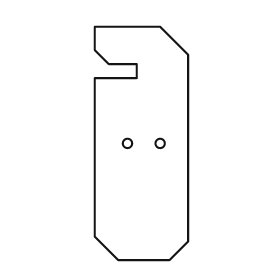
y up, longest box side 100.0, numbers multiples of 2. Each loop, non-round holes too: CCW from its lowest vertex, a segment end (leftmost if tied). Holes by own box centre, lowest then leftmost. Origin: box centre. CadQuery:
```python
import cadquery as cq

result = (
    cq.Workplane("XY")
    .moveTo(-10.0, -50.0)
    .lineTo(12.0, -50.0)
    .lineTo(20.0, -42.0)
    .lineTo(20.0, 38.0)
    .lineTo(8.0, 50.0)
    .lineTo(-20.0, 50.0)
    .lineTo(-20.0, 40.0)
    .lineTo(-14.0, 34.0)
    .lineTo(-2.0, 34.0)
    .lineTo(-2.0, 28.0)
    .lineTo(-20.0, 28.0)
    .lineTo(-20.0, -40.0)
    .close()
    .moveTo(-6.0, 0.0)
    .circle(2.0)
    .moveTo(8.0, 0.0)
    .circle(2.0)
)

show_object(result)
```